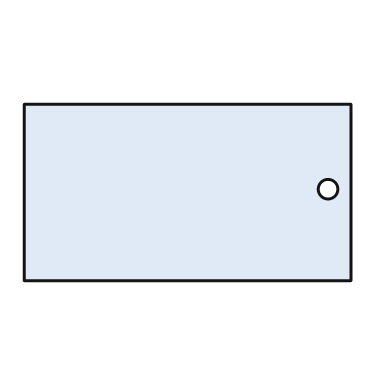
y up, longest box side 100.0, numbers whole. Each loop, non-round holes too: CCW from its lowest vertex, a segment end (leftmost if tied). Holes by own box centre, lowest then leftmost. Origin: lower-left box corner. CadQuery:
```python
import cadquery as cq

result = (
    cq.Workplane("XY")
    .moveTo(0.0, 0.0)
    .lineTo(100.0, 0.0)
    .lineTo(100.0, 54.0)
    .lineTo(0.0, 54.0)
    .close()
    .moveTo(93.0, 28.0)
    .circle(3.0)
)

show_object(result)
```